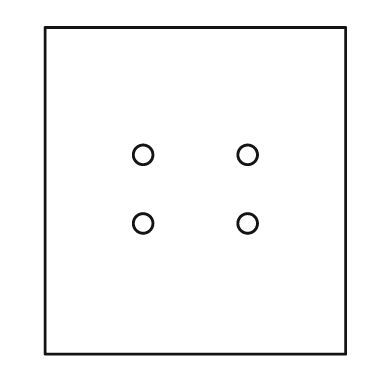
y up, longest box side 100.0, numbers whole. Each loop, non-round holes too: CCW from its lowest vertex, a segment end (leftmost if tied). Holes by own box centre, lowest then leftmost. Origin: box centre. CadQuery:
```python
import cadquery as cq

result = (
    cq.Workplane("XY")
    .moveTo(-46.0, -50.0)
    .lineTo(46.0, -50.0)
    .lineTo(46.0, 50.0)
    .lineTo(-46.0, 50.0)
    .close()
    .moveTo(-16.0, -10.0)
    .circle(3.0)
    .moveTo(16.0, -10.0)
    .circle(3.0)
    .moveTo(-16.0, 11.0)
    .circle(3.0)
    .moveTo(16.0, 11.0)
    .circle(3.0)
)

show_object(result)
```